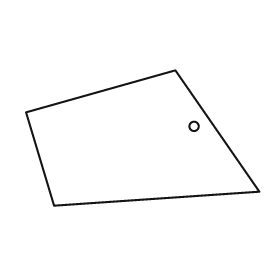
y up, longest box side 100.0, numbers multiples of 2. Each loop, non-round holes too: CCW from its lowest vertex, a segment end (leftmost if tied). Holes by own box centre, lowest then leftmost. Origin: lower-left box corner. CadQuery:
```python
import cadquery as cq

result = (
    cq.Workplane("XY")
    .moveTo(12.0, 0.0)
    .lineTo(100.0, 6.0)
    .lineTo(64.0, 58.0)
    .lineTo(0.0, 40.0)
    .close()
    .moveTo(72.0, 34.0)
    .circle(2.0)
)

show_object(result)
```